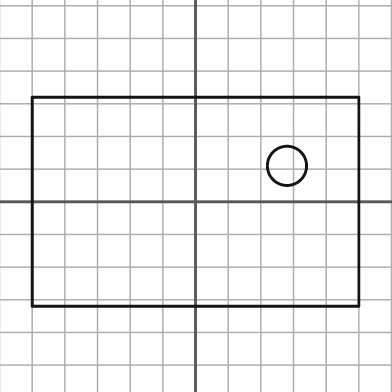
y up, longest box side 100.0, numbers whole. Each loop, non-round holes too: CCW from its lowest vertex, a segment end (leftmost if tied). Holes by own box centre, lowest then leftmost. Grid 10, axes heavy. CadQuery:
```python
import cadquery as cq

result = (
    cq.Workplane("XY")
    .moveTo(-50.0, -32.0)
    .lineTo(50.0, -32.0)
    .lineTo(50.0, 32.0)
    .lineTo(-50.0, 32.0)
    .close()
    .moveTo(28.0, 11.0)
    .circle(6.0)
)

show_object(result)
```